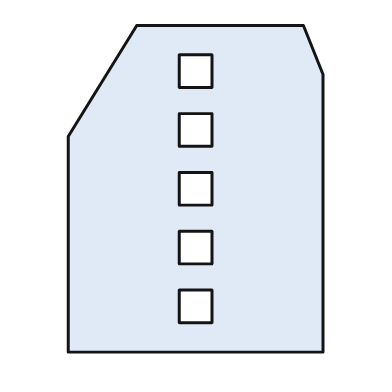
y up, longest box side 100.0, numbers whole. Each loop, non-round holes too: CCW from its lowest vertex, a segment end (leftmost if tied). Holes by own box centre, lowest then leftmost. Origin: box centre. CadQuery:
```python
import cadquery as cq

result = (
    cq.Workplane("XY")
    .moveTo(-39.0, -50.0)
    .lineTo(39.0, -50.0)
    .lineTo(39.0, 35.0)
    .lineTo(33.0, 50.0)
    .lineTo(-18.0, 50.0)
    .lineTo(-39.0, 16.0)
    .close()
    .moveTo(-5.0, -41.0)
    .lineTo(5.0, -41.0)
    .lineTo(5.0, -31.0)
    .lineTo(-5.0, -31.0)
    .close()
    .moveTo(-5.0, -23.0)
    .lineTo(5.0, -23.0)
    .lineTo(5.0, -13.0)
    .lineTo(-5.0, -13.0)
    .close()
    .moveTo(-5.0, -5.0)
    .lineTo(5.0, -5.0)
    .lineTo(5.0, 5.0)
    .lineTo(-5.0, 5.0)
    .close()
    .moveTo(-5.0, 13.0)
    .lineTo(5.0, 13.0)
    .lineTo(5.0, 23.0)
    .lineTo(-5.0, 23.0)
    .close()
    .moveTo(-5.0, 31.0)
    .lineTo(5.0, 31.0)
    .lineTo(5.0, 41.0)
    .lineTo(-5.0, 41.0)
    .close()
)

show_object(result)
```